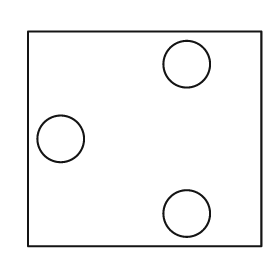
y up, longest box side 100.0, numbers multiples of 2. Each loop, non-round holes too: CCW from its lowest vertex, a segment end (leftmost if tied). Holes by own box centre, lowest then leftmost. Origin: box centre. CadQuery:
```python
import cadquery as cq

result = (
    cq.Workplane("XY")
    .moveTo(-50.0, -46.0)
    .lineTo(50.0, -46.0)
    .lineTo(50.0, 46.0)
    .lineTo(-50.0, 46.0)
    .close()
    .moveTo(18.0, -32.0)
    .circle(10.0)
    .moveTo(-36.0, 0.0)
    .circle(10.0)
    .moveTo(18.0, 32.0)
    .circle(10.0)
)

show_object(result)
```